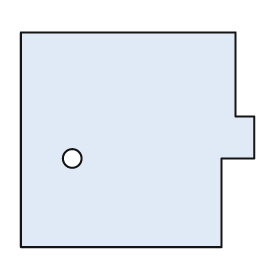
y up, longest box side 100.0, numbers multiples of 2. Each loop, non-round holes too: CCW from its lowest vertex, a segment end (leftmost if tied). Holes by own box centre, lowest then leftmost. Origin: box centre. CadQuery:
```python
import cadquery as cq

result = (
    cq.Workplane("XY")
    .moveTo(-50.0, -46.0)
    .lineTo(36.0, -46.0)
    .lineTo(36.0, -8.0)
    .lineTo(50.0, -8.0)
    .lineTo(50.0, 10.0)
    .lineTo(42.0, 10.0)
    .lineTo(42.0, 46.0)
    .lineTo(-50.0, 46.0)
    .close()
    .moveTo(-28.0, -8.0)
    .circle(4.0)
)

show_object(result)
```